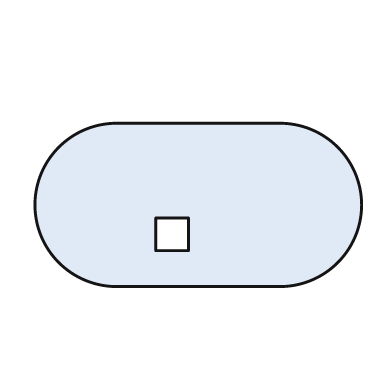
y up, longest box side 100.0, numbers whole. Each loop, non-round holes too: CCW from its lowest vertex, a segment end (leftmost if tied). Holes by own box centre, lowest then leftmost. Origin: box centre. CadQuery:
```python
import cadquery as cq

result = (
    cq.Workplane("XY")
    .moveTo(-25.0, -25.0)
    .lineTo(25.0, -25.0)
    .threePointArc((50.0, 0.0), (25.0, 25.0))
    .lineTo(-25.0, 25.0)
    .threePointArc((-50.0, 0.0), (-25.0, -25.0))
    .close()
    .moveTo(-13.0, -14.0)
    .lineTo(-3.0, -14.0)
    .lineTo(-3.0, -4.0)
    .lineTo(-13.0, -4.0)
    .close()
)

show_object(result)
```